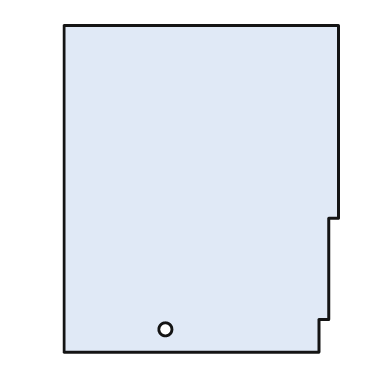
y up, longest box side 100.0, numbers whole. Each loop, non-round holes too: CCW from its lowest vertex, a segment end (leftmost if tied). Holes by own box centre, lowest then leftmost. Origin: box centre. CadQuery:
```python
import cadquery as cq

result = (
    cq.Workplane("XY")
    .moveTo(-42.0, -50.0)
    .lineTo(36.0, -50.0)
    .lineTo(36.0, -40.0)
    .lineTo(39.0, -40.0)
    .lineTo(39.0, -9.0)
    .lineTo(42.0, -9.0)
    .lineTo(42.0, 50.0)
    .lineTo(-42.0, 50.0)
    .close()
    .moveTo(-11.0, -43.0)
    .circle(2.0)
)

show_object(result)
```